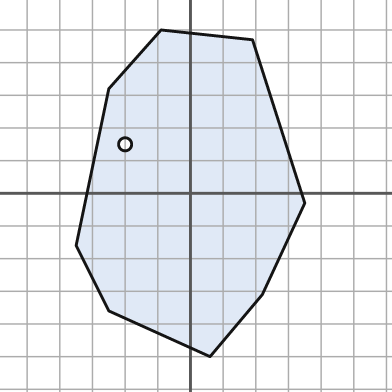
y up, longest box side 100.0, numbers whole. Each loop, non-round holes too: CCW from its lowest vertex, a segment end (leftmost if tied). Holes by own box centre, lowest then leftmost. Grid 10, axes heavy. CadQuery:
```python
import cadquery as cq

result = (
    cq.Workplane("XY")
    .moveTo(6.0, -50.0)
    .lineTo(22.0, -31.0)
    .lineTo(35.0, -3.0)
    .lineTo(19.0, 47.0)
    .lineTo(-9.0, 50.0)
    .lineTo(-25.0, 32.0)
    .lineTo(-35.0, -16.0)
    .lineTo(-25.0, -36.0)
    .close()
    .moveTo(-20.0, 15.0)
    .circle(2.0)
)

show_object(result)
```